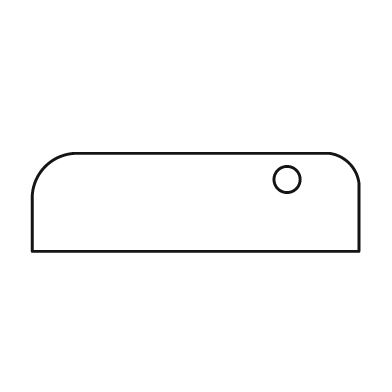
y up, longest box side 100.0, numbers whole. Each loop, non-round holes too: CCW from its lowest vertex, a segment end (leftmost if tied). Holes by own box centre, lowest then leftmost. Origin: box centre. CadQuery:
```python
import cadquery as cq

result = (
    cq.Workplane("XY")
    .moveTo(-50.0, -15.0)
    .lineTo(50.0, -15.0)
    .lineTo(50.0, 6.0)
    .threePointArc((47.0, 12.0), (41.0, 15.0))
    .lineTo(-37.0, 15.0)
    .threePointArc((-46.0, 11.0), (-50.0, 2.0))
    .close()
    .moveTo(28.0, 7.0)
    .circle(4.0)
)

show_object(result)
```